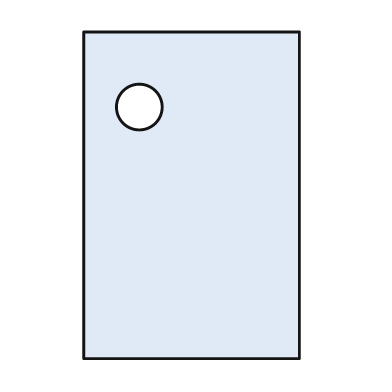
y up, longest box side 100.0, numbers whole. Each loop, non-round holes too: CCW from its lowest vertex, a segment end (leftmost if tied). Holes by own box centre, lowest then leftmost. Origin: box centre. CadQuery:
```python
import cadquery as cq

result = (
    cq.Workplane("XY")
    .moveTo(-33.0, -50.0)
    .lineTo(33.0, -50.0)
    .lineTo(33.0, 50.0)
    .lineTo(-33.0, 50.0)
    .close()
    .moveTo(-16.0, 27.0)
    .circle(7.0)
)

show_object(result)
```